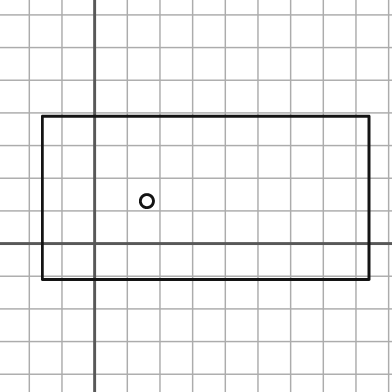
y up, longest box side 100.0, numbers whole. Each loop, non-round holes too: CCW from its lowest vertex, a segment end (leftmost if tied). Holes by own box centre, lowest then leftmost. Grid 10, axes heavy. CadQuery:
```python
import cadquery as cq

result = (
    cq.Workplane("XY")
    .moveTo(-16.0, -11.0)
    .lineTo(84.0, -11.0)
    .lineTo(84.0, 39.0)
    .lineTo(-16.0, 39.0)
    .close()
    .moveTo(16.0, 13.0)
    .circle(2.0)
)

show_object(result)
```